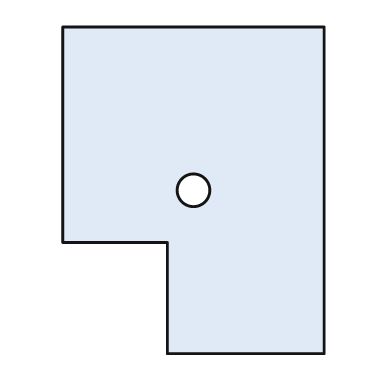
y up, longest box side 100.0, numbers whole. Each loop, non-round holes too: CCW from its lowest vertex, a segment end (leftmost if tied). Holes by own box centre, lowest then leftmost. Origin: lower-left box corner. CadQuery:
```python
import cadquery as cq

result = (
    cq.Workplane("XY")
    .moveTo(32.0, 0.0)
    .lineTo(80.0, 0.0)
    .lineTo(80.0, 100.0)
    .lineTo(0.0, 100.0)
    .lineTo(0.0, 34.0)
    .lineTo(32.0, 34.0)
    .close()
    .moveTo(40.0, 50.0)
    .circle(5.0)
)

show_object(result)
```